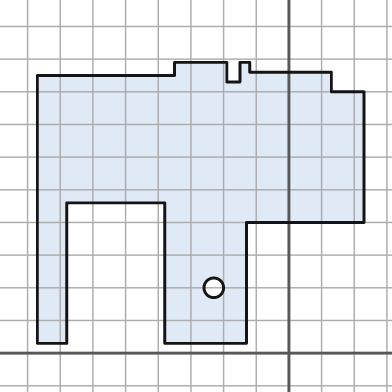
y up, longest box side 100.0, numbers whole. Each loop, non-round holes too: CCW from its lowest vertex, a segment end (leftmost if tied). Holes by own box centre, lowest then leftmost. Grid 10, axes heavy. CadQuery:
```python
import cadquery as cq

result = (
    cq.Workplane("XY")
    .moveTo(-77.0, 3.0)
    .lineTo(-68.0, 3.0)
    .lineTo(-68.0, 46.0)
    .lineTo(-38.0, 46.0)
    .lineTo(-38.0, 3.0)
    .lineTo(-13.0, 3.0)
    .lineTo(-13.0, 40.0)
    .lineTo(23.0, 40.0)
    .lineTo(23.0, 80.0)
    .lineTo(13.0, 80.0)
    .lineTo(13.0, 86.0)
    .lineTo(-12.0, 86.0)
    .lineTo(-12.0, 89.0)
    .lineTo(-15.0, 89.0)
    .lineTo(-15.0, 83.0)
    .lineTo(-19.0, 83.0)
    .lineTo(-19.0, 89.0)
    .lineTo(-35.0, 89.0)
    .lineTo(-35.0, 85.0)
    .lineTo(-77.0, 85.0)
    .close()
    .moveTo(-23.0, 20.0)
    .circle(3.0)
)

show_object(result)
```